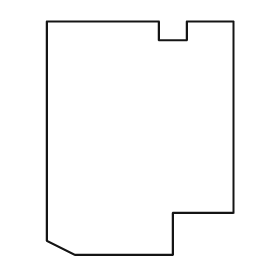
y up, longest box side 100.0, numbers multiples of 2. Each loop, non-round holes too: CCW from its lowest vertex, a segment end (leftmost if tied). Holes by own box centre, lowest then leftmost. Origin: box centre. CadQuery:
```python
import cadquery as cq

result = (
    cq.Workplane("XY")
    .moveTo(-28.0, -50.0)
    .lineTo(14.0, -50.0)
    .lineTo(14.0, -32.0)
    .lineTo(40.0, -32.0)
    .lineTo(40.0, 50.0)
    .lineTo(20.0, 50.0)
    .lineTo(20.0, 42.0)
    .lineTo(8.0, 42.0)
    .lineTo(8.0, 50.0)
    .lineTo(-40.0, 50.0)
    .lineTo(-40.0, -44.0)
    .close()
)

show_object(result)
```